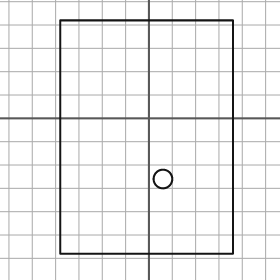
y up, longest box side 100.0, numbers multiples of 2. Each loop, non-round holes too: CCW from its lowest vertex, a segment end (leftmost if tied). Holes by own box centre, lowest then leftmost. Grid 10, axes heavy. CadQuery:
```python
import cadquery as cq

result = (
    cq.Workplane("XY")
    .moveTo(-38.0, -58.0)
    .lineTo(36.0, -58.0)
    .lineTo(36.0, 42.0)
    .lineTo(-38.0, 42.0)
    .close()
    .moveTo(6.0, -26.0)
    .circle(4.0)
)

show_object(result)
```